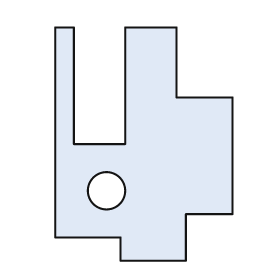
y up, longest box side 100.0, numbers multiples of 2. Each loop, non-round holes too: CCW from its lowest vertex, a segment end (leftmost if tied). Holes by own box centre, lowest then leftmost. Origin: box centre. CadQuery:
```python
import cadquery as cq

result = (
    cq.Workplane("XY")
    .moveTo(-10.0, -50.0)
    .lineTo(18.0, -50.0)
    .lineTo(18.0, -30.0)
    .lineTo(38.0, -30.0)
    .lineTo(38.0, 20.0)
    .lineTo(14.0, 20.0)
    .lineTo(14.0, 50.0)
    .lineTo(-8.0, 50.0)
    .lineTo(-8.0, 0.0)
    .lineTo(-30.0, 0.0)
    .lineTo(-30.0, 50.0)
    .lineTo(-38.0, 50.0)
    .lineTo(-38.0, -40.0)
    .lineTo(-10.0, -40.0)
    .close()
    .moveTo(-16.0, -20.0)
    .circle(8.0)
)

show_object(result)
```